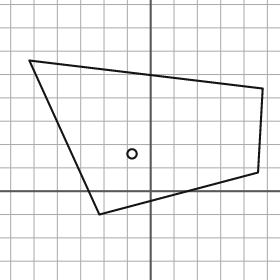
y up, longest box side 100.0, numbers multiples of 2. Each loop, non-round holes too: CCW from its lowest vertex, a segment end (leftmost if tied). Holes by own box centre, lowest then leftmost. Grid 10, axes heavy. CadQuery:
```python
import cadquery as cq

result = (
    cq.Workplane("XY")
    .moveTo(-22.0, -10.0)
    .lineTo(46.0, 8.0)
    .lineTo(48.0, 44.0)
    .lineTo(-52.0, 56.0)
    .close()
    .moveTo(-8.0, 16.0)
    .circle(2.0)
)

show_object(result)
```